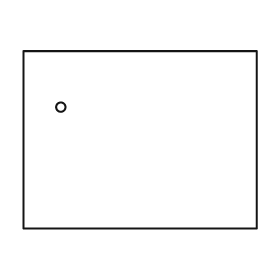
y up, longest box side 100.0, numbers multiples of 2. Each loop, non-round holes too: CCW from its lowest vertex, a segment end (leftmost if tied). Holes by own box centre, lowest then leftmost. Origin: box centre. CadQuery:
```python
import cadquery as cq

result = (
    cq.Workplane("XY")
    .moveTo(-50.0, -38.0)
    .lineTo(50.0, -38.0)
    .lineTo(50.0, 38.0)
    .lineTo(-50.0, 38.0)
    .close()
    .moveTo(-34.0, 14.0)
    .circle(2.0)
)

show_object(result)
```